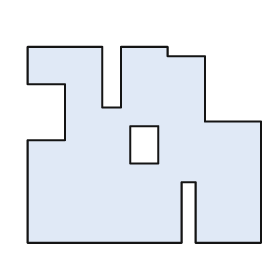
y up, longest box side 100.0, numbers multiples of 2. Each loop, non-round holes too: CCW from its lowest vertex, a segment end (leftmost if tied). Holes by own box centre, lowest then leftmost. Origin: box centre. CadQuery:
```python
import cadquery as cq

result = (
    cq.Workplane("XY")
    .moveTo(-50.0, -42.0)
    .lineTo(16.0, -42.0)
    .lineTo(16.0, -16.0)
    .lineTo(22.0, -16.0)
    .lineTo(22.0, -42.0)
    .lineTo(50.0, -42.0)
    .lineTo(50.0, 10.0)
    .lineTo(26.0, 10.0)
    .lineTo(26.0, 38.0)
    .lineTo(10.0, 38.0)
    .lineTo(10.0, 42.0)
    .lineTo(-10.0, 42.0)
    .lineTo(-10.0, 16.0)
    .lineTo(-18.0, 16.0)
    .lineTo(-18.0, 42.0)
    .lineTo(-50.0, 42.0)
    .lineTo(-50.0, 26.0)
    .lineTo(-34.0, 26.0)
    .lineTo(-34.0, 2.0)
    .lineTo(-50.0, 2.0)
    .close()
    .moveTo(-6.0, -8.0)
    .lineTo(6.0, -8.0)
    .lineTo(6.0, 8.0)
    .lineTo(-6.0, 8.0)
    .close()
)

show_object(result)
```